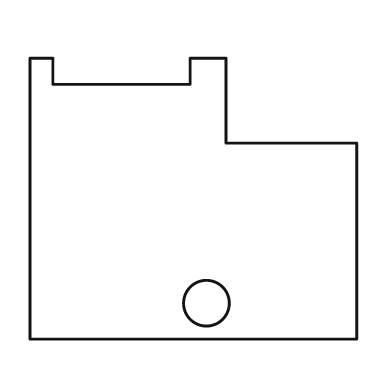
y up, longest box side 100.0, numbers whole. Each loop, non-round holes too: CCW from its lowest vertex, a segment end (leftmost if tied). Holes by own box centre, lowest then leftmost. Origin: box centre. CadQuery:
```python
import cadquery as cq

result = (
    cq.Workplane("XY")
    .moveTo(-50.0, -43.0)
    .lineTo(50.0, -43.0)
    .lineTo(50.0, 17.0)
    .lineTo(10.0, 17.0)
    .lineTo(10.0, 43.0)
    .lineTo(-1.0, 43.0)
    .lineTo(-1.0, 35.0)
    .lineTo(-43.0, 35.0)
    .lineTo(-43.0, 43.0)
    .lineTo(-50.0, 43.0)
    .close()
    .moveTo(4.0, -32.0)
    .circle(7.0)
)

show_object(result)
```